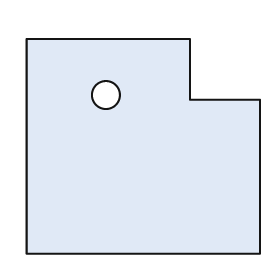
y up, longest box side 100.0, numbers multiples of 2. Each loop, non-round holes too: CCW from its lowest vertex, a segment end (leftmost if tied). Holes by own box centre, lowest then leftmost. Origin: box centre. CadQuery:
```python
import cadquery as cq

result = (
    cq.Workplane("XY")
    .moveTo(-50.0, -46.0)
    .lineTo(50.0, -46.0)
    .lineTo(50.0, 20.0)
    .lineTo(20.0, 20.0)
    .lineTo(20.0, 46.0)
    .lineTo(-50.0, 46.0)
    .close()
    .moveTo(-16.0, 22.0)
    .circle(6.0)
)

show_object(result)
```